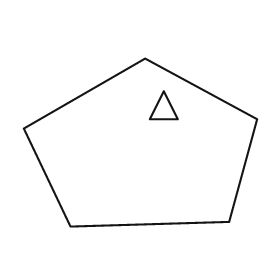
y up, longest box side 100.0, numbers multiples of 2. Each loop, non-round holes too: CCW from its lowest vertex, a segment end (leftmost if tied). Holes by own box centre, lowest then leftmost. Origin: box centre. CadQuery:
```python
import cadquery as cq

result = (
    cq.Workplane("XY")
    .moveTo(-30.0, -36.0)
    .lineTo(38.0, -34.0)
    .lineTo(50.0, 10.0)
    .lineTo(2.0, 36.0)
    .lineTo(-50.0, 6.0)
    .close()
    .moveTo(4.0, 10.0)
    .lineTo(16.0, 10.0)
    .lineTo(10.0, 22.0)
    .close()
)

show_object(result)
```